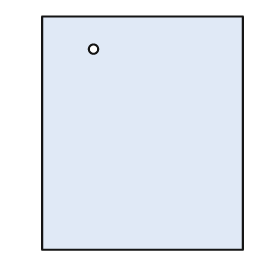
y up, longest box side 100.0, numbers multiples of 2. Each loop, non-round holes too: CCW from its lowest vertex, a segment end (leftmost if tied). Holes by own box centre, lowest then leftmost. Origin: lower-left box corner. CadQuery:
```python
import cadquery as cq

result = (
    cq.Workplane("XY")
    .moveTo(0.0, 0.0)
    .lineTo(86.0, 0.0)
    .lineTo(86.0, 100.0)
    .lineTo(0.0, 100.0)
    .close()
    .moveTo(22.0, 86.0)
    .circle(2.0)
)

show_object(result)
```